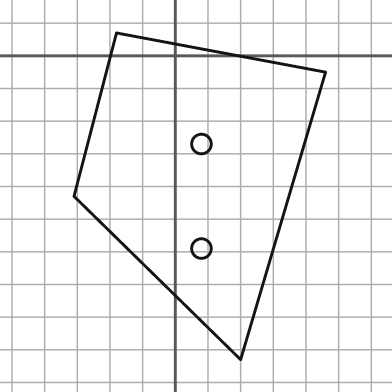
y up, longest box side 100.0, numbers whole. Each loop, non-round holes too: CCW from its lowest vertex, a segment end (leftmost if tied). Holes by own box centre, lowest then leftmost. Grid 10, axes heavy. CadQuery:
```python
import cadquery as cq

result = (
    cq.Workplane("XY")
    .moveTo(20.0, -93.0)
    .lineTo(46.0, -5.0)
    .lineTo(-18.0, 7.0)
    .lineTo(-31.0, -43.0)
    .close()
    .moveTo(8.0, -59.0)
    .circle(3.0)
    .moveTo(8.0, -27.0)
    .circle(3.0)
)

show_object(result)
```